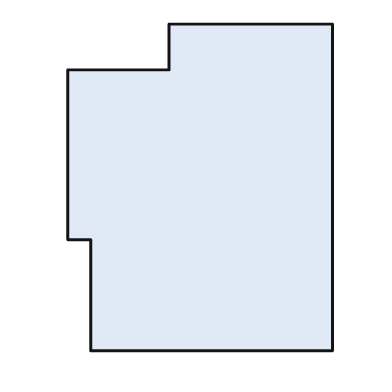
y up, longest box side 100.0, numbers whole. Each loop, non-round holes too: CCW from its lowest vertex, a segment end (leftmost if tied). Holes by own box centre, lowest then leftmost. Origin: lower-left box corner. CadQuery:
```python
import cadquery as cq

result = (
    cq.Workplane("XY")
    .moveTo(7.0, 0.0)
    .lineTo(81.0, 0.0)
    .lineTo(81.0, 100.0)
    .lineTo(31.0, 100.0)
    .lineTo(31.0, 86.0)
    .lineTo(0.0, 86.0)
    .lineTo(0.0, 34.0)
    .lineTo(7.0, 34.0)
    .close()
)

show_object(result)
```